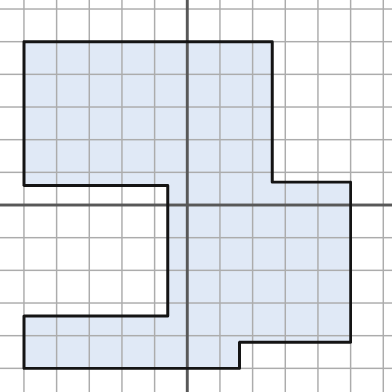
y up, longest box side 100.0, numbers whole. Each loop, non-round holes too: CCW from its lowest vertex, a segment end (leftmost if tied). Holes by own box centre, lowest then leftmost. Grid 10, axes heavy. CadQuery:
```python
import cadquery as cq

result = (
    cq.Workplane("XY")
    .moveTo(-50.0, -50.0)
    .lineTo(16.0, -50.0)
    .lineTo(16.0, -42.0)
    .lineTo(50.0, -42.0)
    .lineTo(50.0, 7.0)
    .lineTo(26.0, 7.0)
    .lineTo(26.0, 50.0)
    .lineTo(-50.0, 50.0)
    .lineTo(-50.0, 6.0)
    .lineTo(-6.0, 6.0)
    .lineTo(-6.0, -34.0)
    .lineTo(-50.0, -34.0)
    .close()
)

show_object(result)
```